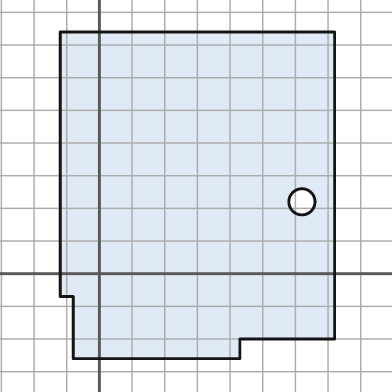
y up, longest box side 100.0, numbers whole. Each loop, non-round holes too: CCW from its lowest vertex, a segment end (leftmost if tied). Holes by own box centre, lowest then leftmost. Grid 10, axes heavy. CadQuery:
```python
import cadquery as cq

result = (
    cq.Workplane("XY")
    .moveTo(-8.0, -26.0)
    .lineTo(43.0, -26.0)
    .lineTo(43.0, -20.0)
    .lineTo(72.0, -20.0)
    .lineTo(72.0, 74.0)
    .lineTo(-12.0, 74.0)
    .lineTo(-12.0, -7.0)
    .lineTo(-8.0, -7.0)
    .close()
    .moveTo(62.0, 22.0)
    .circle(4.0)
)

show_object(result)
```